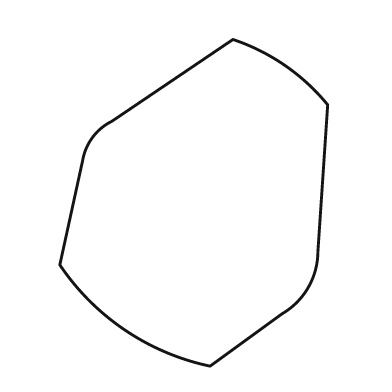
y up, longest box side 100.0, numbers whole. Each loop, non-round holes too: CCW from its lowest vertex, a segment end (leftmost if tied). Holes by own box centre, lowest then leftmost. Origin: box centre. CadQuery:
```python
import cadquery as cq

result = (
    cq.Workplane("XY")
    .moveTo(5.0, -50.0)
    .lineTo(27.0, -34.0)
    .threePointArc((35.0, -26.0), (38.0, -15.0))
    .lineTo(41.0, 30.0)
    .threePointArc((28.0, 42.0), (12.0, 50.0))
    .lineTo(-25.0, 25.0)
    .threePointArc((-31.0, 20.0), (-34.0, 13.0))
    .lineTo(-41.0, -19.0)
    .threePointArc((-21.0, -39.0), (5.0, -50.0))
    .close()
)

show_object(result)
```